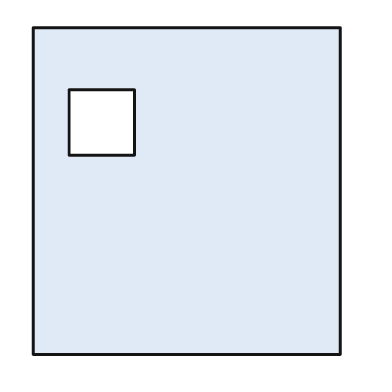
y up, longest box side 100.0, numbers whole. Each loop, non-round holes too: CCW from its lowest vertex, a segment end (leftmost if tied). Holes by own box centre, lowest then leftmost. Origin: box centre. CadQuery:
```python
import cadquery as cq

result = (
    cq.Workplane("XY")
    .moveTo(-47.0, -50.0)
    .lineTo(47.0, -50.0)
    .lineTo(47.0, 50.0)
    .lineTo(-47.0, 50.0)
    .close()
    .moveTo(-36.0, 11.0)
    .lineTo(-16.0, 11.0)
    .lineTo(-16.0, 31.0)
    .lineTo(-36.0, 31.0)
    .close()
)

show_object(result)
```